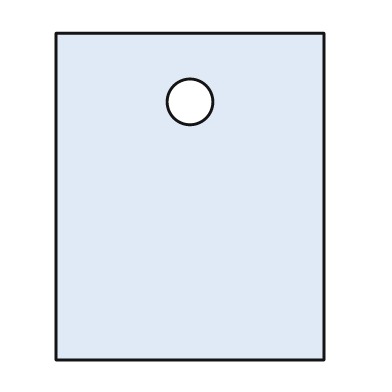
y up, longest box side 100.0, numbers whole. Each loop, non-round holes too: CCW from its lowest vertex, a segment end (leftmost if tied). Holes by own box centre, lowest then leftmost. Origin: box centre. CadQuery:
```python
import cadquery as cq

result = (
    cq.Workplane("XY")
    .moveTo(-41.0, -50.0)
    .lineTo(41.0, -50.0)
    .lineTo(41.0, 50.0)
    .lineTo(-41.0, 50.0)
    .close()
    .moveTo(0.0, 29.0)
    .circle(7.0)
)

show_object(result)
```